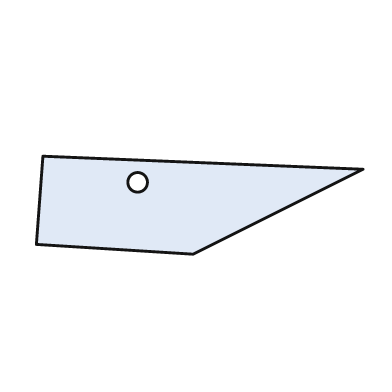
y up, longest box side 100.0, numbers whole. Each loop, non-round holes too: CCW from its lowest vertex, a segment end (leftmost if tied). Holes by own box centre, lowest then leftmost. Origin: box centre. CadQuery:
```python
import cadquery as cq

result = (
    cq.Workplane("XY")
    .moveTo(-2.0, -15.0)
    .lineTo(50.0, 11.0)
    .lineTo(-48.0, 15.0)
    .lineTo(-50.0, -12.0)
    .close()
    .moveTo(-19.0, 7.0)
    .circle(3.0)
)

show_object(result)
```